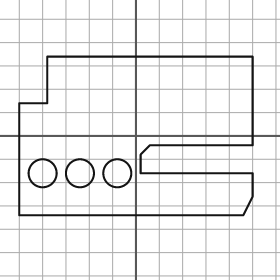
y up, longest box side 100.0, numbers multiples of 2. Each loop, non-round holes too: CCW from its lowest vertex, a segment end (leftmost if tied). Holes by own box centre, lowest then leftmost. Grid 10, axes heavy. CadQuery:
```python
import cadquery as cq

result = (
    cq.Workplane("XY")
    .moveTo(-50.0, -34.0)
    .lineTo(46.0, -34.0)
    .lineTo(50.0, -26.0)
    .lineTo(50.0, -16.0)
    .lineTo(2.0, -16.0)
    .lineTo(2.0, -8.0)
    .lineTo(6.0, -4.0)
    .lineTo(50.0, -4.0)
    .lineTo(50.0, 34.0)
    .lineTo(-38.0, 34.0)
    .lineTo(-38.0, 14.0)
    .lineTo(-50.0, 14.0)
    .close()
    .moveTo(-40.0, -16.0)
    .circle(6.0)
    .moveTo(-24.0, -16.0)
    .circle(6.0)
    .moveTo(-8.0, -16.0)
    .circle(6.0)
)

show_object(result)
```